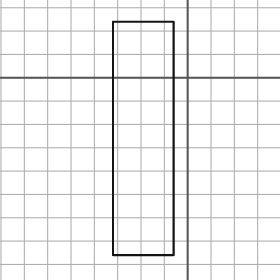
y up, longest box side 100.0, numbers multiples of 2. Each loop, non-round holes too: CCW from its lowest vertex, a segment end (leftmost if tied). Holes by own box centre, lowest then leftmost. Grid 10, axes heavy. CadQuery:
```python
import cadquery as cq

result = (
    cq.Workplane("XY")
    .moveTo(-32.0, -76.0)
    .lineTo(-6.0, -76.0)
    .lineTo(-6.0, 24.0)
    .lineTo(-32.0, 24.0)
    .close()
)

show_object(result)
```